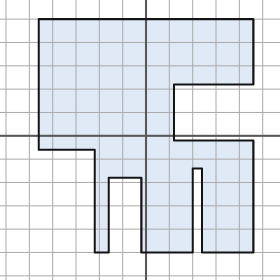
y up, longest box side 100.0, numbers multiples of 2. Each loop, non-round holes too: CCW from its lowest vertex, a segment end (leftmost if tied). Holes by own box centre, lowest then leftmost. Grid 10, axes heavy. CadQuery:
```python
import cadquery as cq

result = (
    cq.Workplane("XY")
    .moveTo(-22.0, -50.0)
    .lineTo(-16.0, -50.0)
    .lineTo(-16.0, -18.0)
    .lineTo(-2.0, -18.0)
    .lineTo(-2.0, -50.0)
    .lineTo(20.0, -50.0)
    .lineTo(20.0, -14.0)
    .lineTo(24.0, -14.0)
    .lineTo(24.0, -50.0)
    .lineTo(46.0, -50.0)
    .lineTo(46.0, -2.0)
    .lineTo(12.0, -2.0)
    .lineTo(12.0, 22.0)
    .lineTo(46.0, 22.0)
    .lineTo(46.0, 50.0)
    .lineTo(-46.0, 50.0)
    .lineTo(-46.0, -6.0)
    .lineTo(-22.0, -6.0)
    .close()
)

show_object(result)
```